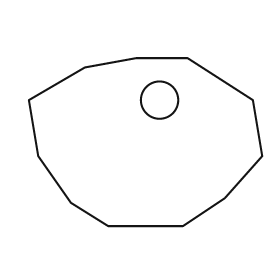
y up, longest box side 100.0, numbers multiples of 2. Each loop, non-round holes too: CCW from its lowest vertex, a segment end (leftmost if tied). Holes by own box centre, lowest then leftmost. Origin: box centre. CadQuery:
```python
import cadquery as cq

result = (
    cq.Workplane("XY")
    .moveTo(-16.0, -36.0)
    .lineTo(16.0, -36.0)
    .lineTo(34.0, -24.0)
    .lineTo(50.0, -6.0)
    .lineTo(46.0, 18.0)
    .lineTo(18.0, 36.0)
    .lineTo(-4.0, 36.0)
    .lineTo(-26.0, 32.0)
    .lineTo(-50.0, 18.0)
    .lineTo(-46.0, -6.0)
    .lineTo(-32.0, -26.0)
    .close()
    .moveTo(6.0, 18.0)
    .circle(8.0)
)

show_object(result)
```